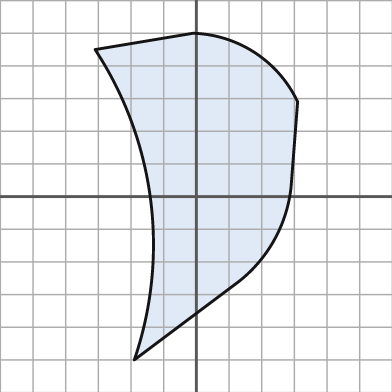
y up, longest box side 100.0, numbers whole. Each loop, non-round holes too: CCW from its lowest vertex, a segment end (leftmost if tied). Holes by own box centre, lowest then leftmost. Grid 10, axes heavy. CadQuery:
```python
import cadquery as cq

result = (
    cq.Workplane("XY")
    .moveTo(-19.0, -50.0)
    .lineTo(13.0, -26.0)
    .threePointArc((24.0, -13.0), (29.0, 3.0))
    .lineTo(31.0, 29.0)
    .threePointArc((18.0, 44.0), (-1.0, 50.0))
    .lineTo(-31.0, 45.0)
    .threePointArc((-14.0, -1.0), (-19.0, -50.0))
    .close()
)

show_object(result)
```